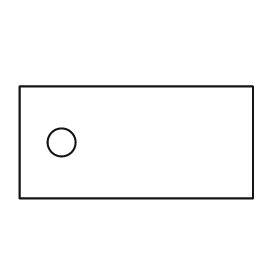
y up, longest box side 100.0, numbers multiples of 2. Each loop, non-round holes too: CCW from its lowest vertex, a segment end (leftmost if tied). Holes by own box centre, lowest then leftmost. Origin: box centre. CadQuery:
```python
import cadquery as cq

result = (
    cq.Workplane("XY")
    .moveTo(-50.0, -24.0)
    .lineTo(50.0, -24.0)
    .lineTo(50.0, 24.0)
    .lineTo(-50.0, 24.0)
    .close()
    .moveTo(-32.0, 0.0)
    .circle(6.0)
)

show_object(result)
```